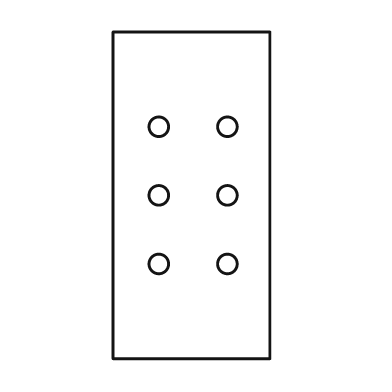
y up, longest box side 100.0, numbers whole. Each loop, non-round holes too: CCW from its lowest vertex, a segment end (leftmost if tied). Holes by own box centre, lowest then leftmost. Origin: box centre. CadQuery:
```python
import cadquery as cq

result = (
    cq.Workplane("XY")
    .moveTo(-24.0, -50.0)
    .lineTo(24.0, -50.0)
    .lineTo(24.0, 50.0)
    .lineTo(-24.0, 50.0)
    .close()
    .moveTo(-10.0, -21.0)
    .circle(3.0)
    .moveTo(11.0, -21.0)
    .circle(3.0)
    .moveTo(-10.0, 0.0)
    .circle(3.0)
    .moveTo(11.0, 0.0)
    .circle(3.0)
    .moveTo(-10.0, 21.0)
    .circle(3.0)
    .moveTo(11.0, 21.0)
    .circle(3.0)
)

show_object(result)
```